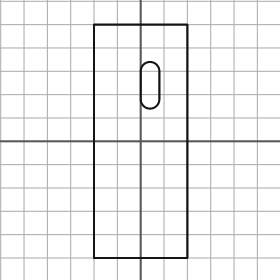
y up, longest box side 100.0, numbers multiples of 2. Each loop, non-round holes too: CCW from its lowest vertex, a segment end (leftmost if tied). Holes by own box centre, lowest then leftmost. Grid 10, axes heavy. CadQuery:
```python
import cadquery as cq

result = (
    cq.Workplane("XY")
    .moveTo(-20.0, -50.0)
    .lineTo(20.0, -50.0)
    .lineTo(20.0, 50.0)
    .lineTo(-20.0, 50.0)
    .close()
    .moveTo(0.0, 18.0)
    .threePointArc((4.0, 14.0), (8.0, 18.0))
    .lineTo(8.0, 30.0)
    .threePointArc((4.0, 34.0), (0.0, 30.0))
    .close()
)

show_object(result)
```